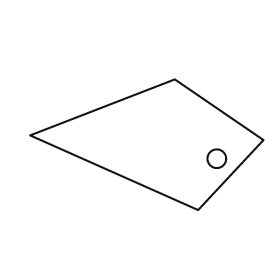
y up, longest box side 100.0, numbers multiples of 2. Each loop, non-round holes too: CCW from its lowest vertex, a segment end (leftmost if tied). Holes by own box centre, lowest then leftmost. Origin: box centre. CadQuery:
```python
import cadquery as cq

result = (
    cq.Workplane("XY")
    .moveTo(22.0, -28.0)
    .lineTo(50.0, 2.0)
    .lineTo(12.0, 28.0)
    .lineTo(-50.0, 4.0)
    .close()
    .moveTo(30.0, -6.0)
    .circle(4.0)
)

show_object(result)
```